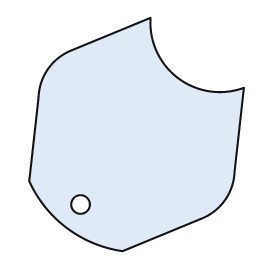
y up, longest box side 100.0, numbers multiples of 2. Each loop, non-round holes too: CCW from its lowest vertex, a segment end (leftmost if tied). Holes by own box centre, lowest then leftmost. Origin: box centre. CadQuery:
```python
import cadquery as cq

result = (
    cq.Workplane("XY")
    .moveTo(-6.0, -50.0)
    .lineTo(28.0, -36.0)
    .threePointArc((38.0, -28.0), (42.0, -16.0))
    .lineTo(46.0, 20.0)
    .threePointArc((18.0, 24.0), (6.0, 50.0))
    .lineTo(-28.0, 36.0)
    .threePointArc((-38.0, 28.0), (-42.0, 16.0))
    .lineTo(-46.0, -20.0)
    .threePointArc((-30.0, -40.0), (-6.0, -50.0))
    .close()
    .moveTo(-24.0, -30.0)
    .circle(4.0)
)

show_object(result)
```